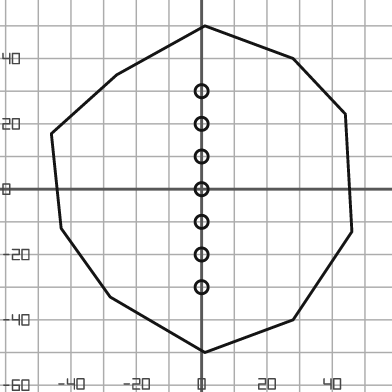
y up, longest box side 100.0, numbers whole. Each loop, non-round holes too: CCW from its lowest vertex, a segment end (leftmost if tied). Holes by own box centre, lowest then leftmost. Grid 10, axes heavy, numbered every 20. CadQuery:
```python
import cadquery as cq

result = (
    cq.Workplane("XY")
    .moveTo(1.0, -50.0)
    .lineTo(28.0, -40.0)
    .lineTo(46.0, -13.0)
    .lineTo(44.0, 23.0)
    .lineTo(28.0, 40.0)
    .lineTo(1.0, 50.0)
    .lineTo(-26.0, 35.0)
    .lineTo(-46.0, 17.0)
    .lineTo(-43.0, -12.0)
    .lineTo(-28.0, -33.0)
    .close()
    .moveTo(0.0, -30.0)
    .circle(2.0)
    .moveTo(0.0, -20.0)
    .circle(2.0)
    .moveTo(0.0, -10.0)
    .circle(2.0)
    .moveTo(0.0, 0.0)
    .circle(2.0)
    .moveTo(0.0, 10.0)
    .circle(2.0)
    .moveTo(0.0, 20.0)
    .circle(2.0)
    .moveTo(0.0, 30.0)
    .circle(2.0)
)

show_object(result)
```